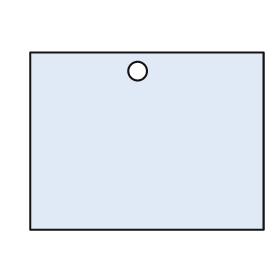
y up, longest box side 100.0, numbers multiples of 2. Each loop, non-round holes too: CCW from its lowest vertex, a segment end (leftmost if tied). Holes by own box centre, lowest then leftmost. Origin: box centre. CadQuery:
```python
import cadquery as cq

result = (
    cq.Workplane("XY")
    .moveTo(-50.0, -38.0)
    .lineTo(50.0, -38.0)
    .lineTo(50.0, 38.0)
    .lineTo(-50.0, 38.0)
    .close()
    .moveTo(-4.0, 30.0)
    .circle(4.0)
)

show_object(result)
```